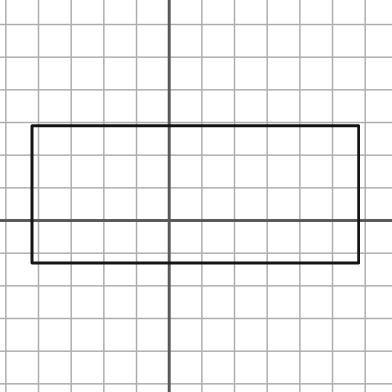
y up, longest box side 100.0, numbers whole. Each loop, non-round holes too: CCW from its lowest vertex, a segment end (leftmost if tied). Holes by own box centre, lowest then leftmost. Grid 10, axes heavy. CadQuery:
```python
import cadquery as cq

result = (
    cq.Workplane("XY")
    .moveTo(-42.0, -13.0)
    .lineTo(58.0, -13.0)
    .lineTo(58.0, 29.0)
    .lineTo(-42.0, 29.0)
    .close()
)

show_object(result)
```